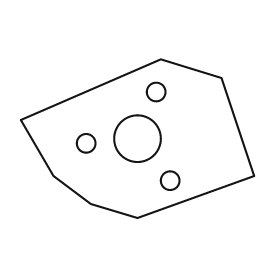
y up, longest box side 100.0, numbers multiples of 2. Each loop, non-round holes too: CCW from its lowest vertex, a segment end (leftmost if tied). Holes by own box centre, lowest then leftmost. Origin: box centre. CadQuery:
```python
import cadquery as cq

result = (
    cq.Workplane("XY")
    .moveTo(0.0, -34.0)
    .lineTo(50.0, -16.0)
    .lineTo(36.0, 26.0)
    .lineTo(10.0, 34.0)
    .lineTo(-50.0, 8.0)
    .lineTo(-36.0, -16.0)
    .lineTo(-20.0, -28.0)
    .close()
    .moveTo(14.0, -18.0)
    .circle(4.0)
    .moveTo(-22.0, -2.0)
    .circle(4.0)
    .moveTo(0.0, 0.0)
    .circle(10.0)
    .moveTo(8.0, 20.0)
    .circle(4.0)
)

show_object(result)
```